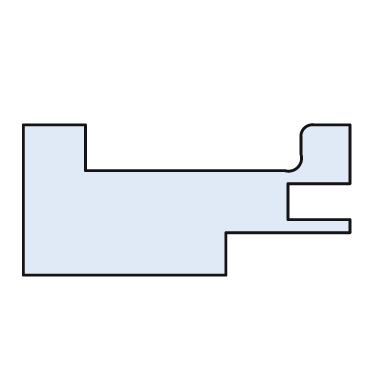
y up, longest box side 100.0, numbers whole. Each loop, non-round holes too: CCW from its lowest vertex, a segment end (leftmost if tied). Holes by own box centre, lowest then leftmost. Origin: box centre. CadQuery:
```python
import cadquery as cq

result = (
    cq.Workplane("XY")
    .moveTo(-50.0, -23.0)
    .lineTo(12.0, -23.0)
    .lineTo(12.0, -10.0)
    .lineTo(50.0, -10.0)
    .lineTo(50.0, -6.0)
    .lineTo(31.0, -6.0)
    .lineTo(31.0, 5.0)
    .lineTo(50.0, 5.0)
    .lineTo(50.0, 23.0)
    .lineTo(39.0, 23.0)
    .threePointArc((36.0, 22.0), (35.0, 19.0))
    .lineTo(35.0, 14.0)
    .threePointArc((34.0, 10.0), (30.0, 9.0))
    .lineTo(-31.0, 9.0)
    .lineTo(-31.0, 23.0)
    .lineTo(-50.0, 23.0)
    .close()
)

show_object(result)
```